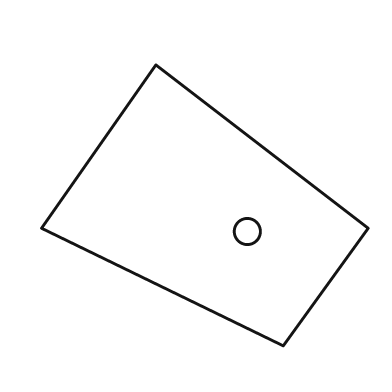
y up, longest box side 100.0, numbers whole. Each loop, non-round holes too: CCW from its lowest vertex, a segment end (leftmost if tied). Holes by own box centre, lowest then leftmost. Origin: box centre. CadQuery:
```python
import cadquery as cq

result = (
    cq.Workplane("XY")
    .moveTo(24.0, -43.0)
    .lineTo(50.0, -7.0)
    .lineTo(-15.0, 43.0)
    .lineTo(-50.0, -7.0)
    .close()
    .moveTo(13.0, -8.0)
    .circle(4.0)
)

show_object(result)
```